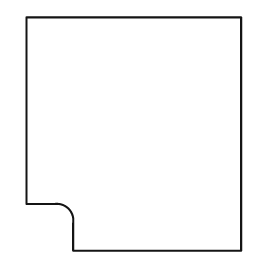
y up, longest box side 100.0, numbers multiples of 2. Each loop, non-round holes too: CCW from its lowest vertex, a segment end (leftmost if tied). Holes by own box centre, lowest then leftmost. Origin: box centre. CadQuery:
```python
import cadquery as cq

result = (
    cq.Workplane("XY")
    .moveTo(-26.0, -50.0)
    .lineTo(46.0, -50.0)
    .lineTo(46.0, 50.0)
    .lineTo(-46.0, 50.0)
    .lineTo(-46.0, -30.0)
    .lineTo(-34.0, -30.0)
    .threePointArc((-28.0, -32.0), (-26.0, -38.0))
    .close()
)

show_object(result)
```